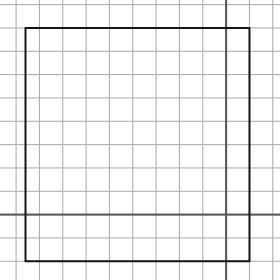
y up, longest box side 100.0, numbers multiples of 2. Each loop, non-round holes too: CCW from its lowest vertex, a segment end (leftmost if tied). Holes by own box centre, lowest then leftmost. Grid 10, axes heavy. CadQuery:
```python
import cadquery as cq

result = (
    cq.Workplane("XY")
    .moveTo(-86.0, -20.0)
    .lineTo(10.0, -20.0)
    .lineTo(10.0, 80.0)
    .lineTo(-86.0, 80.0)
    .close()
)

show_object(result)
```